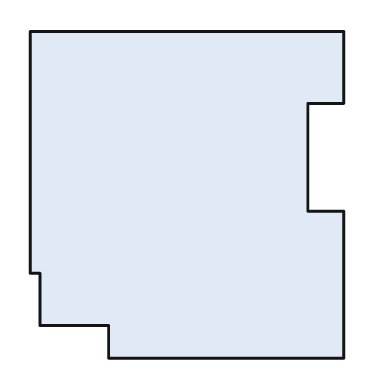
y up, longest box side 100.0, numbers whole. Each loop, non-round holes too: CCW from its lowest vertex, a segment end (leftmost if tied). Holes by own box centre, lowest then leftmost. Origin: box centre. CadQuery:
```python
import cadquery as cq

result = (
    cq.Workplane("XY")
    .moveTo(-24.0, -50.0)
    .lineTo(48.0, -50.0)
    .lineTo(48.0, -5.0)
    .lineTo(37.0, -5.0)
    .lineTo(37.0, 28.0)
    .lineTo(48.0, 28.0)
    .lineTo(48.0, 50.0)
    .lineTo(-48.0, 50.0)
    .lineTo(-48.0, -24.0)
    .lineTo(-45.0, -24.0)
    .lineTo(-45.0, -40.0)
    .lineTo(-24.0, -40.0)
    .close()
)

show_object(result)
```